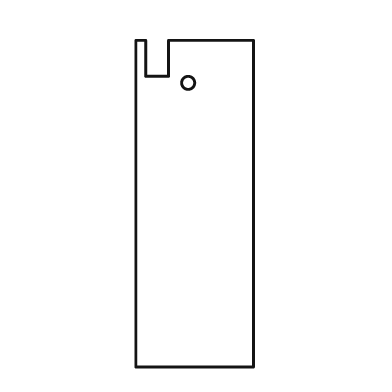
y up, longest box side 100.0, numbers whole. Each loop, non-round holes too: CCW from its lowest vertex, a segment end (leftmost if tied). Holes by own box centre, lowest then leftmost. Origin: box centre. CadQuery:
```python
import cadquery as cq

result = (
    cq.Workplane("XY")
    .moveTo(-18.0, -50.0)
    .lineTo(18.0, -50.0)
    .lineTo(18.0, 50.0)
    .lineTo(-8.0, 50.0)
    .lineTo(-8.0, 39.0)
    .lineTo(-15.0, 39.0)
    .lineTo(-15.0, 50.0)
    .lineTo(-18.0, 50.0)
    .close()
    .moveTo(-2.0, 37.0)
    .circle(2.0)
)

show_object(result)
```